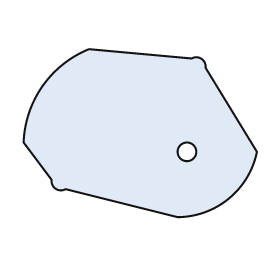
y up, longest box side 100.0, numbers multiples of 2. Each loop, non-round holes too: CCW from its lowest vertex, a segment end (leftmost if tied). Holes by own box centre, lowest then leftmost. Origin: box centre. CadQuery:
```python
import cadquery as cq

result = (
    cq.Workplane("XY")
    .moveTo(16.0, -36.0)
    .threePointArc((38.0, -28.0), (50.0, -8.0))
    .lineTo(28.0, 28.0)
    .threePointArc((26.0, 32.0), (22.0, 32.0))
    .lineTo(-22.0, 36.0)
    .threePointArc((-42.0, 20.0), (-50.0, -4.0))
    .lineTo(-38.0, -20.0)
    .threePointArc((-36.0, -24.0), (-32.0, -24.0))
    .close()
    .moveTo(20.0, -8.0)
    .circle(4.0)
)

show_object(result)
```